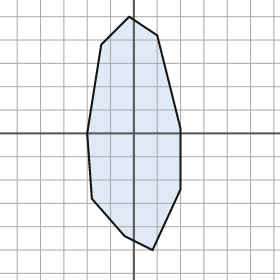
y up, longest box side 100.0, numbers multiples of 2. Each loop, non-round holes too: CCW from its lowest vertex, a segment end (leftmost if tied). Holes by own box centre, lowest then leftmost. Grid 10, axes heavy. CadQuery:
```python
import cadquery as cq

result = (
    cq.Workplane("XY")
    .moveTo(8.0, -50.0)
    .lineTo(20.0, -24.0)
    .lineTo(20.0, 2.0)
    .lineTo(10.0, 42.0)
    .lineTo(-2.0, 50.0)
    .lineTo(-14.0, 38.0)
    .lineTo(-20.0, 0.0)
    .lineTo(-18.0, -28.0)
    .lineTo(-4.0, -44.0)
    .close()
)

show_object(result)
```